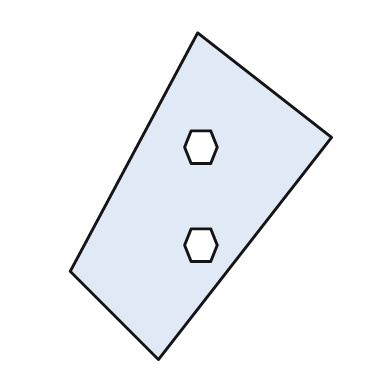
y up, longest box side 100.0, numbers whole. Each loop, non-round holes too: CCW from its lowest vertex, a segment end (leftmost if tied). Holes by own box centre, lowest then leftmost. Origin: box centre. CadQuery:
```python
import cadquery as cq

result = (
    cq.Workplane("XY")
    .moveTo(-13.0, -50.0)
    .lineTo(40.0, 18.0)
    .lineTo(-1.0, 50.0)
    .lineTo(-40.0, -23.0)
    .close()
    .moveTo(-3.0, -20.0)
    .lineTo(3.0, -20.0)
    .lineTo(5.0, -15.0)
    .lineTo(3.0, -10.0)
    .lineTo(-3.0, -10.0)
    .lineTo(-5.0, -15.0)
    .close()
    .moveTo(-3.0, 10.0)
    .lineTo(3.0, 10.0)
    .lineTo(5.0, 15.0)
    .lineTo(3.0, 20.0)
    .lineTo(-3.0, 20.0)
    .lineTo(-5.0, 15.0)
    .close()
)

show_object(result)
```